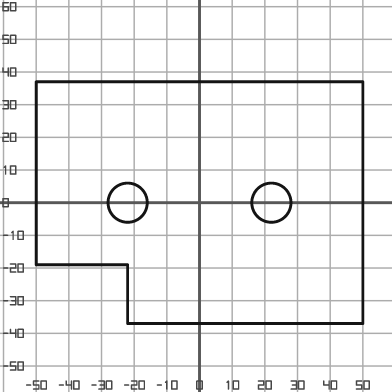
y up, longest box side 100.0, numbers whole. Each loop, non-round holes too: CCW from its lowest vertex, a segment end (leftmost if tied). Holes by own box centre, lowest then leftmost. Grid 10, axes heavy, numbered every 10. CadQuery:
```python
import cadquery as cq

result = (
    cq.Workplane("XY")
    .moveTo(-22.0, -37.0)
    .lineTo(50.0, -37.0)
    .lineTo(50.0, 37.0)
    .lineTo(-50.0, 37.0)
    .lineTo(-50.0, -19.0)
    .lineTo(-22.0, -19.0)
    .close()
    .moveTo(-22.0, 0.0)
    .circle(6.0)
    .moveTo(22.0, 0.0)
    .circle(6.0)
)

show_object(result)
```